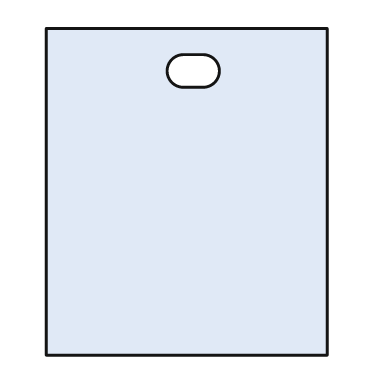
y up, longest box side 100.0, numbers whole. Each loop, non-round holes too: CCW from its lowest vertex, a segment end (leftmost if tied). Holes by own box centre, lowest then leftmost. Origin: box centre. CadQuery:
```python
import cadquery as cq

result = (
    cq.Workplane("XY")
    .moveTo(-43.0, -50.0)
    .lineTo(43.0, -50.0)
    .lineTo(43.0, 50.0)
    .lineTo(-43.0, 50.0)
    .close()
    .moveTo(-1.0, 32.0)
    .lineTo(5.0, 32.0)
    .threePointArc((10.0, 37.0), (5.0, 42.0))
    .lineTo(-1.0, 42.0)
    .threePointArc((-6.0, 37.0), (-1.0, 32.0))
    .close()
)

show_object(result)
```